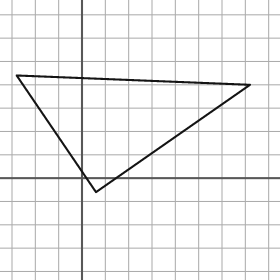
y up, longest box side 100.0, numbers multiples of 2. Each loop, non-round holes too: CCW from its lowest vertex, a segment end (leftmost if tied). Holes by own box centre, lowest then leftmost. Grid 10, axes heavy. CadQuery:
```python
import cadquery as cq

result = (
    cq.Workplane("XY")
    .moveTo(6.0, -6.0)
    .lineTo(72.0, 40.0)
    .lineTo(-28.0, 44.0)
    .close()
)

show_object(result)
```